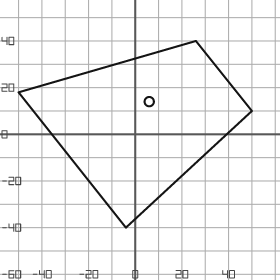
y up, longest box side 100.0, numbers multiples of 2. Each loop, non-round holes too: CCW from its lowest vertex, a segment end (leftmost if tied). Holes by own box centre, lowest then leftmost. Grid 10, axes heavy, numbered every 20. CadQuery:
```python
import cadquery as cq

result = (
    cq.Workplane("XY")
    .moveTo(-4.0, -40.0)
    .lineTo(50.0, 10.0)
    .lineTo(26.0, 40.0)
    .lineTo(-50.0, 18.0)
    .close()
    .moveTo(6.0, 14.0)
    .circle(2.0)
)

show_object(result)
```